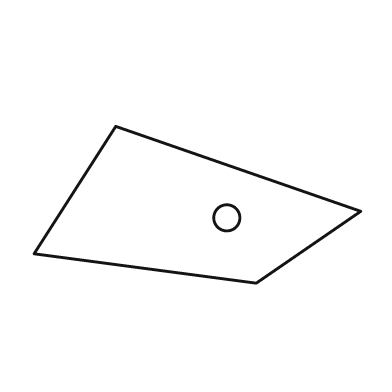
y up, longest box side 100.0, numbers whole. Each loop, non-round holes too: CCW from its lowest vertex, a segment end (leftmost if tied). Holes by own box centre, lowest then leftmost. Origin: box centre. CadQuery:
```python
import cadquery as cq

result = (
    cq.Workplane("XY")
    .moveTo(18.0, -24.0)
    .lineTo(50.0, -2.0)
    .lineTo(-25.0, 24.0)
    .lineTo(-50.0, -15.0)
    .close()
    .moveTo(9.0, -4.0)
    .circle(4.0)
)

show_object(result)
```